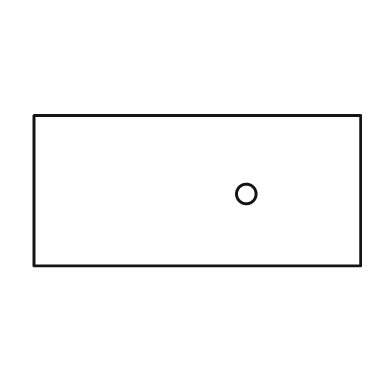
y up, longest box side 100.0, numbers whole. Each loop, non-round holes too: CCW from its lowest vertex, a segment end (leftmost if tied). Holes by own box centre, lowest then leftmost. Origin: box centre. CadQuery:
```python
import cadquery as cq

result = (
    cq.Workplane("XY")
    .moveTo(-50.0, -23.0)
    .lineTo(50.0, -23.0)
    .lineTo(50.0, 23.0)
    .lineTo(-50.0, 23.0)
    .close()
    .moveTo(15.0, -1.0)
    .circle(3.0)
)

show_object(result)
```